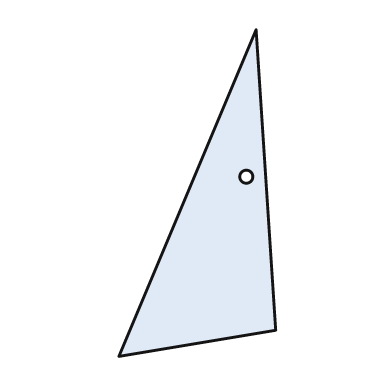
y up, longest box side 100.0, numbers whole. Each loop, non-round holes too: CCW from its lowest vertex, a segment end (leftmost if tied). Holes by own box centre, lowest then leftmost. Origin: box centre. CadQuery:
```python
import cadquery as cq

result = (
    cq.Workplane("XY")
    .moveTo(-24.0, -50.0)
    .lineTo(24.0, -42.0)
    .lineTo(18.0, 50.0)
    .close()
    .moveTo(15.0, 5.0)
    .circle(2.0)
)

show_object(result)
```